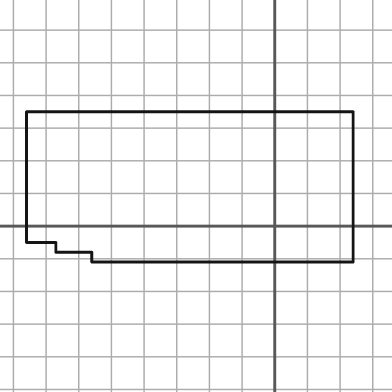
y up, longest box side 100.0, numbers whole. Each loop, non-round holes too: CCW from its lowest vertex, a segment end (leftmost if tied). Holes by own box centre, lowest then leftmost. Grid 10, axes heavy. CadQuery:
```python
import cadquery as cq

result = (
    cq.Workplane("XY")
    .moveTo(-56.0, -11.0)
    .lineTo(24.0, -11.0)
    .lineTo(24.0, 35.0)
    .lineTo(-76.0, 35.0)
    .lineTo(-76.0, -5.0)
    .lineTo(-67.0, -5.0)
    .lineTo(-67.0, -8.0)
    .lineTo(-56.0, -8.0)
    .close()
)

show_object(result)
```